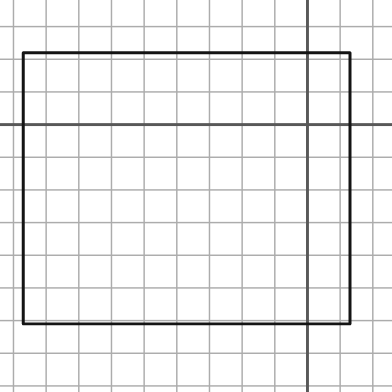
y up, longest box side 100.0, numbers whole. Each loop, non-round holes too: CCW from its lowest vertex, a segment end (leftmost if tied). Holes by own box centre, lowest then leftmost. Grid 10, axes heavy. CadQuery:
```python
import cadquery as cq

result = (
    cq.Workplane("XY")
    .moveTo(-87.0, -61.0)
    .lineTo(13.0, -61.0)
    .lineTo(13.0, 22.0)
    .lineTo(-87.0, 22.0)
    .close()
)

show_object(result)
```